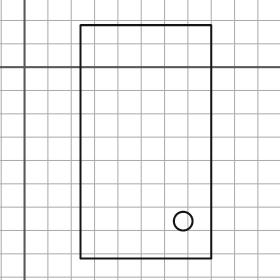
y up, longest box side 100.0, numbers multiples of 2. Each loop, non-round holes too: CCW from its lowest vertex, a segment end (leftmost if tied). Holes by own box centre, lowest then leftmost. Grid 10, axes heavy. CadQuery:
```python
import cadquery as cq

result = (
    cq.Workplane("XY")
    .moveTo(24.0, -82.0)
    .lineTo(80.0, -82.0)
    .lineTo(80.0, 18.0)
    .lineTo(24.0, 18.0)
    .close()
    .moveTo(68.0, -66.0)
    .circle(4.0)
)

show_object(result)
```